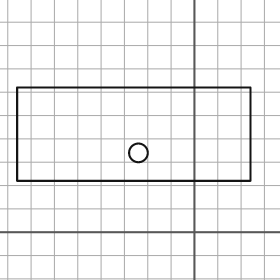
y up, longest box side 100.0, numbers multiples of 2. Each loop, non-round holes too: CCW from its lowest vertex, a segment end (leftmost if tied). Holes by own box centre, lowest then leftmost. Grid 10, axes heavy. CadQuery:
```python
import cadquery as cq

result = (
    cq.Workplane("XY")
    .moveTo(-76.0, 22.0)
    .lineTo(24.0, 22.0)
    .lineTo(24.0, 62.0)
    .lineTo(-76.0, 62.0)
    .close()
    .moveTo(-24.0, 34.0)
    .circle(4.0)
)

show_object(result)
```